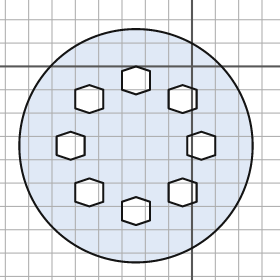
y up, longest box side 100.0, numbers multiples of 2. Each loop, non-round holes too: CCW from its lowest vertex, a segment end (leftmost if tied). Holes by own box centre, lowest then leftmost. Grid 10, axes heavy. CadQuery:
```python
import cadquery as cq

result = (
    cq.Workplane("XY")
    .moveTo(-24.0, -34.0)
    .circle(50.0)
    .moveTo(-24.0, -68.0)
    .lineTo(-18.0, -66.0)
    .lineTo(-18.0, -58.0)
    .lineTo(-24.0, -56.0)
    .lineTo(-30.0, -58.0)
    .lineTo(-30.0, -66.0)
    .close()
    .moveTo(-44.0, -60.0)
    .lineTo(-38.0, -58.0)
    .lineTo(-38.0, -50.0)
    .lineTo(-44.0, -48.0)
    .lineTo(-50.0, -50.0)
    .lineTo(-50.0, -58.0)
    .close()
    .moveTo(-4.0, -60.0)
    .lineTo(2.0, -58.0)
    .lineTo(2.0, -50.0)
    .lineTo(-4.0, -48.0)
    .lineTo(-10.0, -50.0)
    .lineTo(-10.0, -58.0)
    .close()
    .moveTo(-52.0, -40.0)
    .lineTo(-46.0, -38.0)
    .lineTo(-46.0, -30.0)
    .lineTo(-52.0, -28.0)
    .lineTo(-58.0, -30.0)
    .lineTo(-58.0, -38.0)
    .close()
    .moveTo(4.0, -40.0)
    .lineTo(10.0, -38.0)
    .lineTo(10.0, -30.0)
    .lineTo(4.0, -28.0)
    .lineTo(-2.0, -30.0)
    .lineTo(-2.0, -38.0)
    .close()
    .moveTo(-44.0, -20.0)
    .lineTo(-38.0, -18.0)
    .lineTo(-38.0, -10.0)
    .lineTo(-44.0, -8.0)
    .lineTo(-50.0, -10.0)
    .lineTo(-50.0, -18.0)
    .close()
    .moveTo(-4.0, -20.0)
    .lineTo(2.0, -18.0)
    .lineTo(2.0, -10.0)
    .lineTo(-4.0, -8.0)
    .lineTo(-10.0, -10.0)
    .lineTo(-10.0, -18.0)
    .close()
    .moveTo(-24.0, -12.0)
    .lineTo(-18.0, -10.0)
    .lineTo(-18.0, -2.0)
    .lineTo(-24.0, 0.0)
    .lineTo(-30.0, -2.0)
    .lineTo(-30.0, -10.0)
    .close()
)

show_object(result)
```